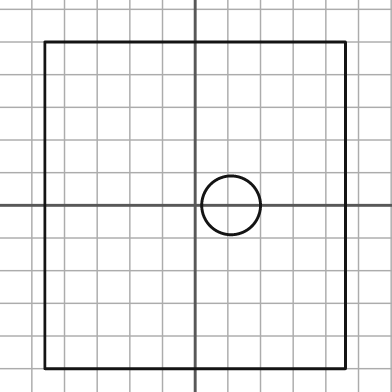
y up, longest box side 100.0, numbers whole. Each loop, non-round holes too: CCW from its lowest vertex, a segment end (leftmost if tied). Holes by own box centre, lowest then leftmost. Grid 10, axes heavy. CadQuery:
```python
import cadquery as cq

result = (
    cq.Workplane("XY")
    .moveTo(-46.0, -50.0)
    .lineTo(46.0, -50.0)
    .lineTo(46.0, 50.0)
    .lineTo(-46.0, 50.0)
    .close()
    .moveTo(11.0, 0.0)
    .circle(9.0)
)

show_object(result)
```